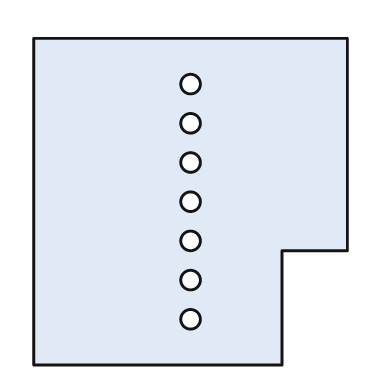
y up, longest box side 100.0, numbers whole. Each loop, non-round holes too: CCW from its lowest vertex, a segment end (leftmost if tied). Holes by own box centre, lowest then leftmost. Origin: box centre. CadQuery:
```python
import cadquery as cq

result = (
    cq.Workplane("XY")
    .moveTo(-48.0, -50.0)
    .lineTo(28.0, -50.0)
    .lineTo(28.0, -15.0)
    .lineTo(48.0, -15.0)
    .lineTo(48.0, 50.0)
    .lineTo(-48.0, 50.0)
    .close()
    .moveTo(0.0, -36.0)
    .circle(3.0)
    .moveTo(0.0, -24.0)
    .circle(3.0)
    .moveTo(0.0, -12.0)
    .circle(3.0)
    .moveTo(0.0, 0.0)
    .circle(3.0)
    .moveTo(0.0, 12.0)
    .circle(3.0)
    .moveTo(0.0, 24.0)
    .circle(3.0)
    .moveTo(0.0, 36.0)
    .circle(3.0)
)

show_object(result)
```